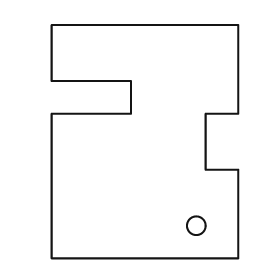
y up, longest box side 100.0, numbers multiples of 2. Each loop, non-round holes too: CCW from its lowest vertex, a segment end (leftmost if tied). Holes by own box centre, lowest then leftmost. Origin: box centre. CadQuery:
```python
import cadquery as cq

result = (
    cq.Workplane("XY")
    .moveTo(-40.0, -50.0)
    .lineTo(40.0, -50.0)
    .lineTo(40.0, -12.0)
    .lineTo(26.0, -12.0)
    .lineTo(26.0, 12.0)
    .lineTo(40.0, 12.0)
    .lineTo(40.0, 50.0)
    .lineTo(-40.0, 50.0)
    .lineTo(-40.0, 26.0)
    .lineTo(-6.0, 26.0)
    .lineTo(-6.0, 12.0)
    .lineTo(-40.0, 12.0)
    .close()
    .moveTo(22.0, -36.0)
    .circle(4.0)
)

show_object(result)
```